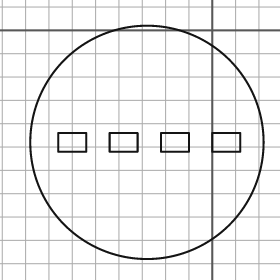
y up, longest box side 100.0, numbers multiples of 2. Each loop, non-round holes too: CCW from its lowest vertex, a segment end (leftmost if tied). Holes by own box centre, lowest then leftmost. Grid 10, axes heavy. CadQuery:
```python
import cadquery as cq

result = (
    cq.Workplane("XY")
    .moveTo(-28.0, -48.0)
    .circle(50.0)
    .moveTo(-66.0, -52.0)
    .lineTo(-54.0, -52.0)
    .lineTo(-54.0, -44.0)
    .lineTo(-66.0, -44.0)
    .close()
    .moveTo(-44.0, -52.0)
    .lineTo(-32.0, -52.0)
    .lineTo(-32.0, -44.0)
    .lineTo(-44.0, -44.0)
    .close()
    .moveTo(-22.0, -52.0)
    .lineTo(-10.0, -52.0)
    .lineTo(-10.0, -44.0)
    .lineTo(-22.0, -44.0)
    .close()
    .moveTo(0.0, -52.0)
    .lineTo(12.0, -52.0)
    .lineTo(12.0, -44.0)
    .lineTo(0.0, -44.0)
    .close()
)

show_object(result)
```